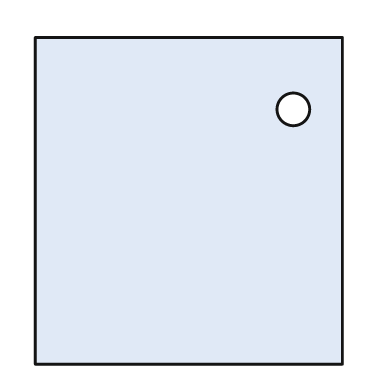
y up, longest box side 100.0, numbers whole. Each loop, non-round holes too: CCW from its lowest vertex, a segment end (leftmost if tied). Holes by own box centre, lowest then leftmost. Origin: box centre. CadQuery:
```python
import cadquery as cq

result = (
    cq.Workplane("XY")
    .moveTo(-47.0, -50.0)
    .lineTo(47.0, -50.0)
    .lineTo(47.0, 50.0)
    .lineTo(-47.0, 50.0)
    .close()
    .moveTo(32.0, 28.0)
    .circle(5.0)
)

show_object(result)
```